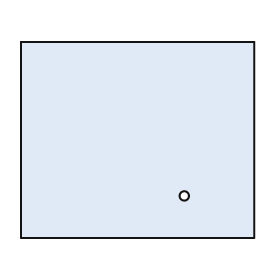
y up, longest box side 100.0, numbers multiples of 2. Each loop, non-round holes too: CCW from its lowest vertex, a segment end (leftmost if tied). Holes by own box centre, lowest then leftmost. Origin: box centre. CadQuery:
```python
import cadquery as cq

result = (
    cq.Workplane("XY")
    .moveTo(-50.0, -42.0)
    .lineTo(50.0, -42.0)
    .lineTo(50.0, 42.0)
    .lineTo(-50.0, 42.0)
    .close()
    .moveTo(20.0, -24.0)
    .circle(2.0)
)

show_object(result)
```